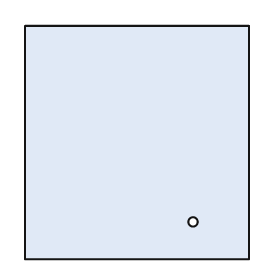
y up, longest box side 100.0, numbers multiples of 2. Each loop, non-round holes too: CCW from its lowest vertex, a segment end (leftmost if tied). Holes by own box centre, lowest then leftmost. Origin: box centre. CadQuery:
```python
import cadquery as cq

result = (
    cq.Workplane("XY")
    .moveTo(-48.0, -50.0)
    .lineTo(48.0, -50.0)
    .lineTo(48.0, 50.0)
    .lineTo(-48.0, 50.0)
    .close()
    .moveTo(24.0, -34.0)
    .circle(2.0)
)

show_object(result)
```